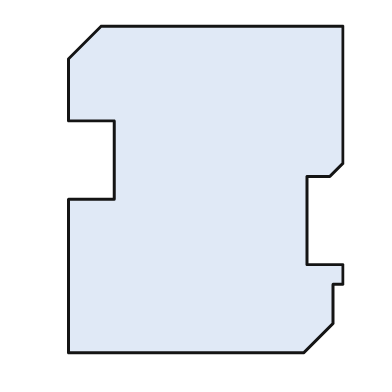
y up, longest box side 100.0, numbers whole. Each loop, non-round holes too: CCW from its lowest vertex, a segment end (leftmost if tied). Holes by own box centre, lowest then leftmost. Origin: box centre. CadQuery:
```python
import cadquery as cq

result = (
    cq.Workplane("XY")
    .moveTo(-42.0, -50.0)
    .lineTo(30.0, -50.0)
    .lineTo(39.0, -41.0)
    .lineTo(39.0, -29.0)
    .lineTo(42.0, -29.0)
    .lineTo(42.0, -23.0)
    .lineTo(31.0, -23.0)
    .lineTo(31.0, 4.0)
    .lineTo(38.0, 4.0)
    .lineTo(42.0, 8.0)
    .lineTo(42.0, 50.0)
    .lineTo(-32.0, 50.0)
    .lineTo(-42.0, 40.0)
    .lineTo(-42.0, 21.0)
    .lineTo(-28.0, 21.0)
    .lineTo(-28.0, -3.0)
    .lineTo(-42.0, -3.0)
    .close()
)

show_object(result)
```